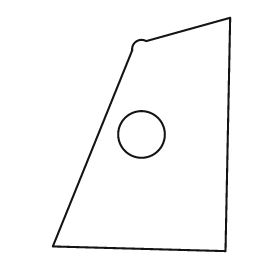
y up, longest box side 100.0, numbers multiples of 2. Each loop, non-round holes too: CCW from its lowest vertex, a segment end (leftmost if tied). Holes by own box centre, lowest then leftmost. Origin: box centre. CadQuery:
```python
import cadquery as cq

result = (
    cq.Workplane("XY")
    .moveTo(36.0, -50.0)
    .lineTo(38.0, 50.0)
    .lineTo(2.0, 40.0)
    .threePointArc((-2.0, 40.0), (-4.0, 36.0))
    .lineTo(-38.0, -48.0)
    .close()
    .moveTo(0.0, 0.0)
    .circle(10.0)
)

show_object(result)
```